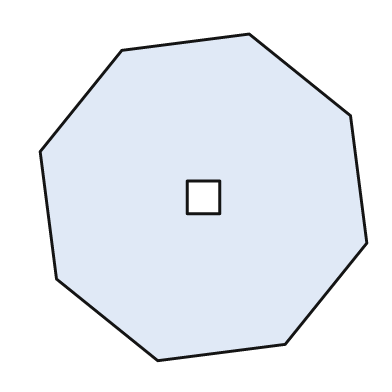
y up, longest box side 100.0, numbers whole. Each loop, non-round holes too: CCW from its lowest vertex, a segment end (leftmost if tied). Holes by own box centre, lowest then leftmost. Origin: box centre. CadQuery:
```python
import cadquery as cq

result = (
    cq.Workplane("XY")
    .moveTo(-14.0, -50.0)
    .lineTo(25.0, -45.0)
    .lineTo(50.0, -14.0)
    .lineTo(45.0, 25.0)
    .lineTo(14.0, 50.0)
    .lineTo(-25.0, 45.0)
    .lineTo(-50.0, 14.0)
    .lineTo(-45.0, -25.0)
    .close()
    .moveTo(-5.0, -5.0)
    .lineTo(5.0, -5.0)
    .lineTo(5.0, 5.0)
    .lineTo(-5.0, 5.0)
    .close()
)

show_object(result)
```